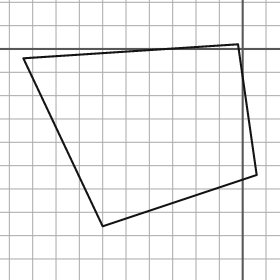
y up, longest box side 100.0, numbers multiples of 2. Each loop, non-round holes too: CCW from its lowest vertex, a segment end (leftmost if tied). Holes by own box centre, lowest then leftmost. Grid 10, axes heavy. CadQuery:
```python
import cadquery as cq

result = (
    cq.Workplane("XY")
    .moveTo(-60.0, -76.0)
    .lineTo(6.0, -54.0)
    .lineTo(-2.0, 2.0)
    .lineTo(-94.0, -4.0)
    .close()
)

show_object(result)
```